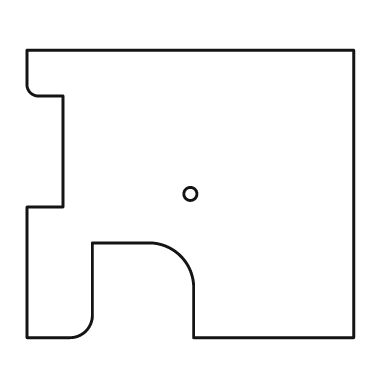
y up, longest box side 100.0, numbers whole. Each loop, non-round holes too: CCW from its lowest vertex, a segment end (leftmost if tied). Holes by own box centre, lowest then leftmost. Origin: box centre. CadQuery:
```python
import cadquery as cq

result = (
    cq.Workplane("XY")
    .moveTo(-50.0, -44.0)
    .lineTo(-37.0, -44.0)
    .threePointArc((-32.0, -42.0), (-30.0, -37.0))
    .lineTo(-30.0, -15.0)
    .lineTo(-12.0, -15.0)
    .threePointArc((-3.0, -19.0), (1.0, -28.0))
    .lineTo(1.0, -44.0)
    .lineTo(50.0, -44.0)
    .lineTo(50.0, 44.0)
    .lineTo(-50.0, 44.0)
    .lineTo(-50.0, 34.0)
    .threePointArc((-49.0, 31.0), (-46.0, 30.0))
    .lineTo(-39.0, 30.0)
    .lineTo(-39.0, -4.0)
    .lineTo(-50.0, -4.0)
    .close()
    .moveTo(0.0, 0.0)
    .circle(2.0)
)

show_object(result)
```